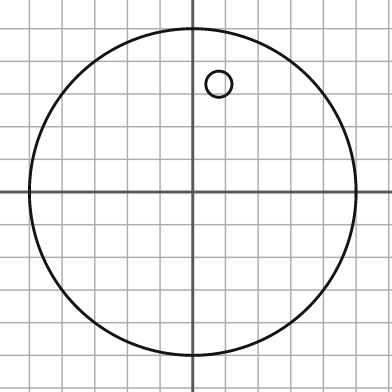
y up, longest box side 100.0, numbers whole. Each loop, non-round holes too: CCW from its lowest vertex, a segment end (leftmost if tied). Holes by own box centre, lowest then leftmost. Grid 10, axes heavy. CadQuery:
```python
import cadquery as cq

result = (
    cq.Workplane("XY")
    .moveTo(0.0, 0.0)
    .circle(50.0)
    .moveTo(8.0, 33.0)
    .circle(4.0)
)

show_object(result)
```